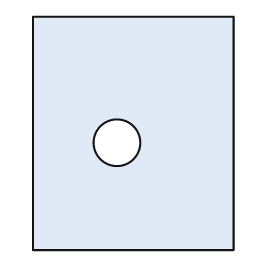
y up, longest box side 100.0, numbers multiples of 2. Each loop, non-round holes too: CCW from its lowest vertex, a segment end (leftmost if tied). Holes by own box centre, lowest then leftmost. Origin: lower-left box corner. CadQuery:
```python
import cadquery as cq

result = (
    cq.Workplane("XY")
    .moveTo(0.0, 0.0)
    .lineTo(86.0, 0.0)
    .lineTo(86.0, 100.0)
    .lineTo(0.0, 100.0)
    .close()
    .moveTo(36.0, 46.0)
    .circle(10.0)
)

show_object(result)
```